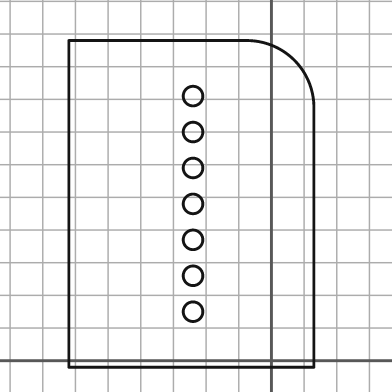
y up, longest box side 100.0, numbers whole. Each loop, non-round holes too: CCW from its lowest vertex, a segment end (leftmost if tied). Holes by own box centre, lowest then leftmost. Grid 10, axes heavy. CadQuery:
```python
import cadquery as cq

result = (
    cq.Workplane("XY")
    .moveTo(-62.0, -2.0)
    .lineTo(13.0, -2.0)
    .lineTo(13.0, 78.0)
    .threePointArc((7.0, 92.0), (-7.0, 98.0))
    .lineTo(-62.0, 98.0)
    .close()
    .moveTo(-24.0, 15.0)
    .circle(3.0)
    .moveTo(-24.0, 26.0)
    .circle(3.0)
    .moveTo(-24.0, 37.0)
    .circle(3.0)
    .moveTo(-24.0, 48.0)
    .circle(3.0)
    .moveTo(-24.0, 59.0)
    .circle(3.0)
    .moveTo(-24.0, 70.0)
    .circle(3.0)
    .moveTo(-24.0, 81.0)
    .circle(3.0)
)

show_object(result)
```